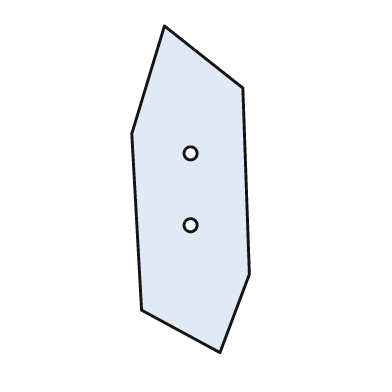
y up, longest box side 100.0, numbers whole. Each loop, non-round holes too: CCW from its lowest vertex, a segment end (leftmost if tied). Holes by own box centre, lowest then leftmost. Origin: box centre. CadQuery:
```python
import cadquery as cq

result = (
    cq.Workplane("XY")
    .moveTo(9.0, -50.0)
    .lineTo(18.0, -26.0)
    .lineTo(16.0, 31.0)
    .lineTo(-8.0, 50.0)
    .lineTo(-18.0, 17.0)
    .lineTo(-15.0, -37.0)
    .close()
    .moveTo(0.0, -11.0)
    .circle(2.0)
    .moveTo(0.0, 11.0)
    .circle(2.0)
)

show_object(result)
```